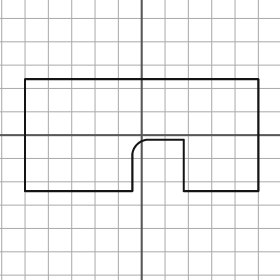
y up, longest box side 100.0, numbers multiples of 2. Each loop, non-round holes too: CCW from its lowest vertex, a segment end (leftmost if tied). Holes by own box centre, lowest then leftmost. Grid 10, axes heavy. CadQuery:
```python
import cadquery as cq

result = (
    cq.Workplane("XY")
    .moveTo(-50.0, -24.0)
    .lineTo(-4.0, -24.0)
    .lineTo(-4.0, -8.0)
    .threePointArc((-2.0, -4.0), (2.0, -2.0))
    .lineTo(18.0, -2.0)
    .lineTo(18.0, -24.0)
    .lineTo(50.0, -24.0)
    .lineTo(50.0, 24.0)
    .lineTo(-50.0, 24.0)
    .close()
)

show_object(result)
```